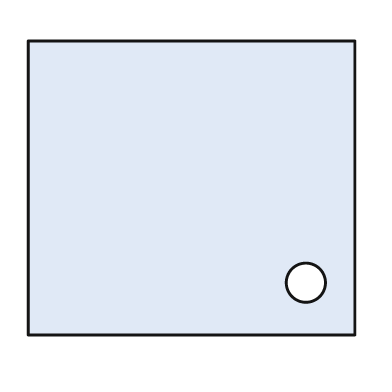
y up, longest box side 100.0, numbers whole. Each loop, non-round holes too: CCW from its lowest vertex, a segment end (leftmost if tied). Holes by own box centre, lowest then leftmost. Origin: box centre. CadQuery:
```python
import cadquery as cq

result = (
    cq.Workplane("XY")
    .moveTo(-50.0, -45.0)
    .lineTo(50.0, -45.0)
    .lineTo(50.0, 45.0)
    .lineTo(-50.0, 45.0)
    .close()
    .moveTo(35.0, -29.0)
    .circle(6.0)
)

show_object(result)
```